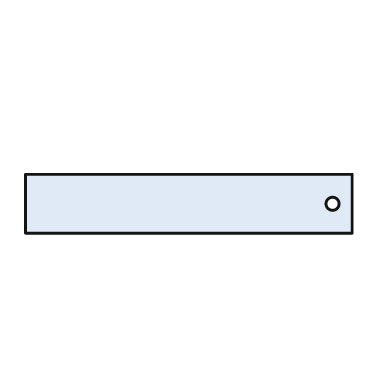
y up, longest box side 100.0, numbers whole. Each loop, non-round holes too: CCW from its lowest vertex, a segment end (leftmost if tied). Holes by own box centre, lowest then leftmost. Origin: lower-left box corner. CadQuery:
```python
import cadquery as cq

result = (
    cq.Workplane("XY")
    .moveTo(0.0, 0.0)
    .lineTo(100.0, 0.0)
    .lineTo(100.0, 18.0)
    .lineTo(0.0, 18.0)
    .close()
    .moveTo(94.0, 9.0)
    .circle(2.0)
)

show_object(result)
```